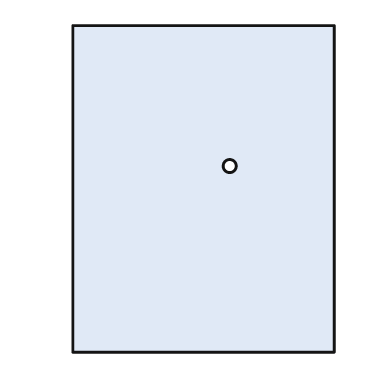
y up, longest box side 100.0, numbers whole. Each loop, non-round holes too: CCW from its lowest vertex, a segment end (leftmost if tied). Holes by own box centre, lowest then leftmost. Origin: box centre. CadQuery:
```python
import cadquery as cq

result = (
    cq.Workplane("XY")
    .moveTo(-40.0, -50.0)
    .lineTo(40.0, -50.0)
    .lineTo(40.0, 50.0)
    .lineTo(-40.0, 50.0)
    .close()
    .moveTo(8.0, 7.0)
    .circle(2.0)
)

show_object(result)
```